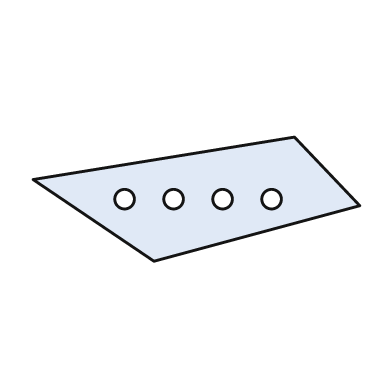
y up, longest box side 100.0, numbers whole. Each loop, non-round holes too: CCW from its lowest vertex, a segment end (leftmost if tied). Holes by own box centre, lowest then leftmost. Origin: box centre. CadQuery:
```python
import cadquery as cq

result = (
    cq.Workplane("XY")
    .moveTo(-13.0, -19.0)
    .lineTo(50.0, -2.0)
    .lineTo(30.0, 19.0)
    .lineTo(-50.0, 6.0)
    .close()
    .moveTo(-22.0, 0.0)
    .circle(3.0)
    .moveTo(-7.0, 0.0)
    .circle(3.0)
    .moveTo(8.0, 0.0)
    .circle(3.0)
    .moveTo(23.0, 0.0)
    .circle(3.0)
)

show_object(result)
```